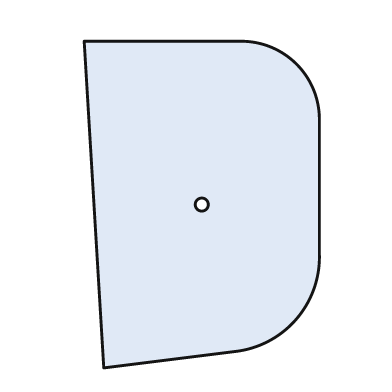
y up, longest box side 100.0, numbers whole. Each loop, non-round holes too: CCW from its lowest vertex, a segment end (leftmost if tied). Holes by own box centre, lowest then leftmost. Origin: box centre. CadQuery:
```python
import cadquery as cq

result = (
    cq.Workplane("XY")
    .moveTo(-30.0, -50.0)
    .lineTo(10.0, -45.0)
    .threePointArc((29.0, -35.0), (36.0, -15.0))
    .lineTo(36.0, 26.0)
    .threePointArc((29.0, 43.0), (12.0, 50.0))
    .lineTo(-36.0, 50.0)
    .close()
    .moveTo(0.0, 0.0)
    .circle(2.0)
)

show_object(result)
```